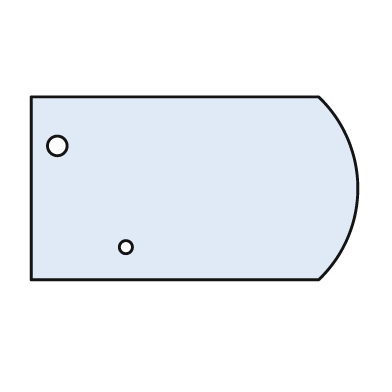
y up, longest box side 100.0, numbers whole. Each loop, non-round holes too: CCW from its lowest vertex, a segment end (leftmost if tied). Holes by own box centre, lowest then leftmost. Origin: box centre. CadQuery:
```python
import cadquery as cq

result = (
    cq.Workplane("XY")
    .moveTo(-50.0, -28.0)
    .lineTo(38.0, -28.0)
    .threePointArc((50.0, 0.0), (38.0, 28.0))
    .lineTo(-50.0, 28.0)
    .close()
    .moveTo(-21.0, -18.0)
    .circle(2.0)
    .moveTo(-42.0, 13.0)
    .circle(3.0)
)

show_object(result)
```